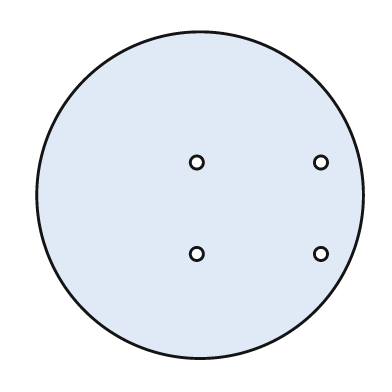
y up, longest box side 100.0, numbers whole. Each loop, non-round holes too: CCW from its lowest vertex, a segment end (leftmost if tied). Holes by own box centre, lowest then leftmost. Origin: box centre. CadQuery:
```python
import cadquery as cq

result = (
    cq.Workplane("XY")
    .moveTo(0.0, 0.0)
    .circle(50.0)
    .moveTo(-1.0, -18.0)
    .circle(2.0)
    .moveTo(37.0, -18.0)
    .circle(2.0)
    .moveTo(-1.0, 10.0)
    .circle(2.0)
    .moveTo(37.0, 10.0)
    .circle(2.0)
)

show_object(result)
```